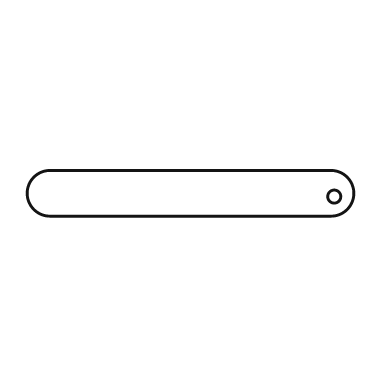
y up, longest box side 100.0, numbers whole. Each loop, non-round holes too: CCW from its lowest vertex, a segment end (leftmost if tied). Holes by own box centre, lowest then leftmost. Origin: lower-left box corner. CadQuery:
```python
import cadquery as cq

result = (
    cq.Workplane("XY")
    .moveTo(7.0, 0.0)
    .lineTo(93.0, 0.0)
    .threePointArc((100.0, 7.0), (93.0, 14.0))
    .lineTo(7.0, 14.0)
    .threePointArc((0.0, 7.0), (7.0, 0.0))
    .close()
    .moveTo(94.0, 6.0)
    .circle(2.0)
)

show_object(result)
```